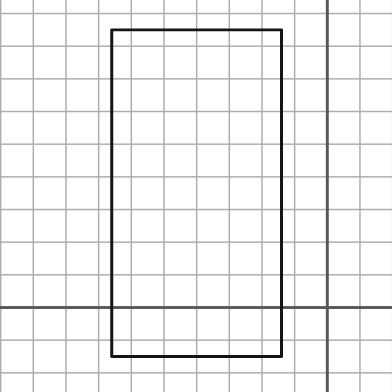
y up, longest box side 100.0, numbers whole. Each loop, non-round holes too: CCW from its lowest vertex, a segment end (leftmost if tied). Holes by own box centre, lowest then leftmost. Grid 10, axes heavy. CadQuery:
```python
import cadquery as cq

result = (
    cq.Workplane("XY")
    .moveTo(-66.0, -15.0)
    .lineTo(-14.0, -15.0)
    .lineTo(-14.0, 85.0)
    .lineTo(-66.0, 85.0)
    .close()
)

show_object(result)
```